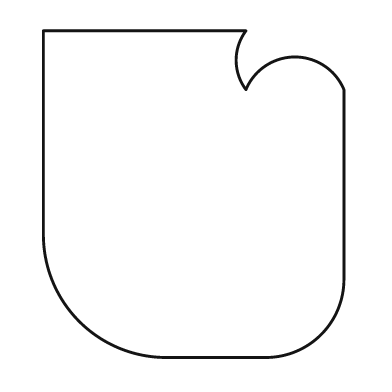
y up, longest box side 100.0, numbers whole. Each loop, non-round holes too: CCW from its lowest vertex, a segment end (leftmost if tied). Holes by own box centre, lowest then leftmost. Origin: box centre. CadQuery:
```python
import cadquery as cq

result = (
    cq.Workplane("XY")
    .moveTo(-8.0, -50.0)
    .lineTo(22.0, -50.0)
    .threePointArc((39.0, -43.0), (46.0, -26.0))
    .lineTo(46.0, 32.0)
    .threePointArc((31.0, 42.0), (16.0, 32.0))
    .threePointArc((13.0, 41.0), (16.0, 50.0))
    .lineTo(-46.0, 50.0)
    .lineTo(-46.0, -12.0)
    .threePointArc((-35.0, -39.0), (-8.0, -50.0))
    .close()
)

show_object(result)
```